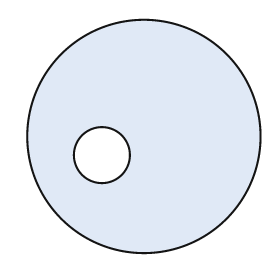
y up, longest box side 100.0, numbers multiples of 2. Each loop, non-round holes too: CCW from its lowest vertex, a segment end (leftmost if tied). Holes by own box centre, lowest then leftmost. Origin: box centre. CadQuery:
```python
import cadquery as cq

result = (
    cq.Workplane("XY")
    .moveTo(0.0, 0.0)
    .circle(50.0)
    .moveTo(-18.0, -8.0)
    .circle(12.0)
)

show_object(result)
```